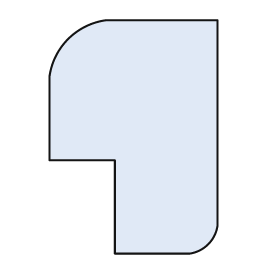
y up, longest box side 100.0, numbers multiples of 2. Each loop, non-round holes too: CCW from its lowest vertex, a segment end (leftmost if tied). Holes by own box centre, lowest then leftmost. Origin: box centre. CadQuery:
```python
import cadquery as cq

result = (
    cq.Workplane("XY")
    .moveTo(-8.0, -50.0)
    .lineTo(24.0, -50.0)
    .threePointArc((32.0, -46.0), (36.0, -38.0))
    .lineTo(36.0, 50.0)
    .lineTo(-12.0, 50.0)
    .threePointArc((-28.0, 42.0), (-36.0, 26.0))
    .lineTo(-36.0, -10.0)
    .lineTo(-8.0, -10.0)
    .close()
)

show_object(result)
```